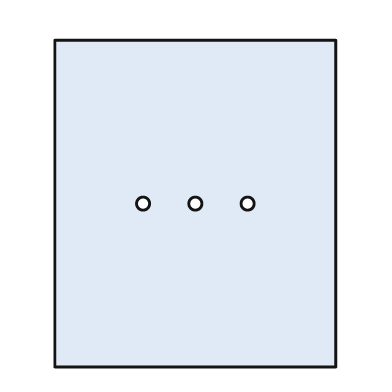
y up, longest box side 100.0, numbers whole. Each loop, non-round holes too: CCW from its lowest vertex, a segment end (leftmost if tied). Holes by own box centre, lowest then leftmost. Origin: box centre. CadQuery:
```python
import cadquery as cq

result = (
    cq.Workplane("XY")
    .moveTo(-43.0, -50.0)
    .lineTo(43.0, -50.0)
    .lineTo(43.0, 50.0)
    .lineTo(-43.0, 50.0)
    .close()
    .moveTo(-16.0, 0.0)
    .circle(2.0)
    .moveTo(0.0, 0.0)
    .circle(2.0)
    .moveTo(16.0, 0.0)
    .circle(2.0)
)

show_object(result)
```